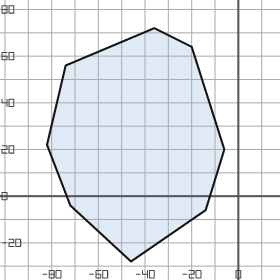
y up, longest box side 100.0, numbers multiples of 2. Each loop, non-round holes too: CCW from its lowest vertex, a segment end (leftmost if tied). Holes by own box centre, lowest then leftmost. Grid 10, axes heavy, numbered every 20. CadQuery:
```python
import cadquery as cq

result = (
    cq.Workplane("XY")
    .moveTo(-46.0, -28.0)
    .lineTo(-14.0, -6.0)
    .lineTo(-6.0, 20.0)
    .lineTo(-20.0, 64.0)
    .lineTo(-36.0, 72.0)
    .lineTo(-74.0, 56.0)
    .lineTo(-82.0, 22.0)
    .lineTo(-72.0, -4.0)
    .close()
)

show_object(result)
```